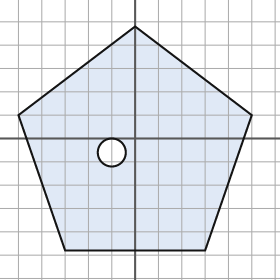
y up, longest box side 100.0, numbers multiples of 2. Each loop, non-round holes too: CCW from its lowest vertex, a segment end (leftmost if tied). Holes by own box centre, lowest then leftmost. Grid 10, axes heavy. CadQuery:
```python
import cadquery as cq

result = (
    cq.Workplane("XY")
    .moveTo(-30.0, -48.0)
    .lineTo(30.0, -48.0)
    .lineTo(50.0, 10.0)
    .lineTo(0.0, 48.0)
    .lineTo(-50.0, 10.0)
    .close()
    .moveTo(-10.0, -6.0)
    .circle(6.0)
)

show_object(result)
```